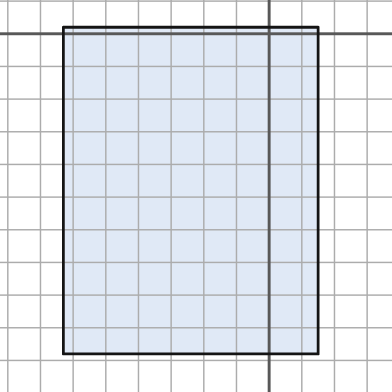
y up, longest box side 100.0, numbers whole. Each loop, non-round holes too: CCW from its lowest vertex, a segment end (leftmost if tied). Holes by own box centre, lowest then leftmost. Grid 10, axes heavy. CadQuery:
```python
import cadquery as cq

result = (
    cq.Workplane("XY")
    .moveTo(-63.0, -98.0)
    .lineTo(15.0, -98.0)
    .lineTo(15.0, 2.0)
    .lineTo(-63.0, 2.0)
    .close()
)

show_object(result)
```